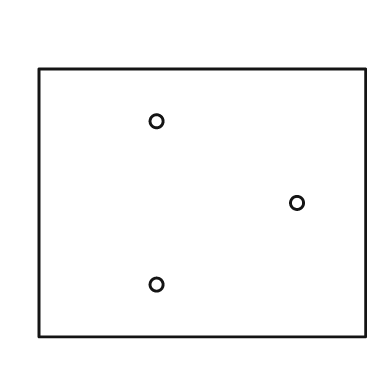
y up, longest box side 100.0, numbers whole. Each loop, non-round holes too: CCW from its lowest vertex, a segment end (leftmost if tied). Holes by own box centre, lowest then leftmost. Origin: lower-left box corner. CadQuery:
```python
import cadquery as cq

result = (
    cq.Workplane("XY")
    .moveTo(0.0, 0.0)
    .lineTo(100.0, 0.0)
    .lineTo(100.0, 82.0)
    .lineTo(0.0, 82.0)
    .close()
    .moveTo(36.0, 16.0)
    .circle(2.0)
    .moveTo(79.0, 41.0)
    .circle(2.0)
    .moveTo(36.0, 66.0)
    .circle(2.0)
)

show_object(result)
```